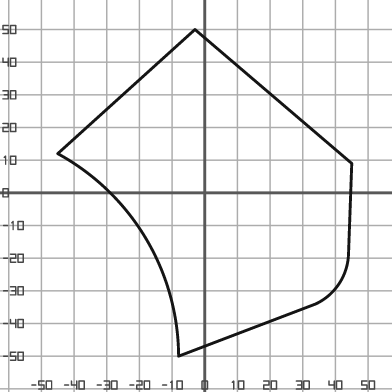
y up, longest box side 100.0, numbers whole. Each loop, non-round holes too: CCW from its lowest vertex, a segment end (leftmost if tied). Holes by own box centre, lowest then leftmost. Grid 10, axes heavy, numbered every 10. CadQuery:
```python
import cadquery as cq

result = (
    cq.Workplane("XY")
    .moveTo(-8.0, -50.0)
    .lineTo(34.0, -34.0)
    .threePointArc((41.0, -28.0), (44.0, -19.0))
    .lineTo(45.0, 9.0)
    .lineTo(-3.0, 50.0)
    .lineTo(-45.0, 12.0)
    .threePointArc((-18.0, -14.0), (-8.0, -50.0))
    .close()
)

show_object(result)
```